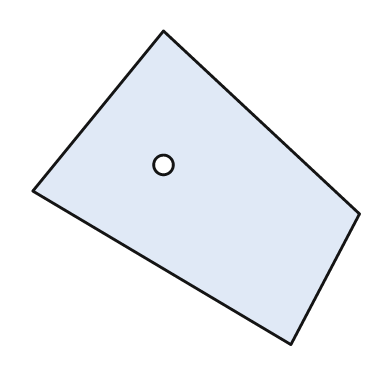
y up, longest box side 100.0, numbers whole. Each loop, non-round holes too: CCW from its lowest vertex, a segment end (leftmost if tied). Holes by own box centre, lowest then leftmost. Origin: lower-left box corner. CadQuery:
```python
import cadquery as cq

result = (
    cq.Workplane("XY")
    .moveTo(79.0, 0.0)
    .lineTo(100.0, 40.0)
    .lineTo(40.0, 96.0)
    .lineTo(0.0, 47.0)
    .close()
    .moveTo(40.0, 55.0)
    .circle(3.0)
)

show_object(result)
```